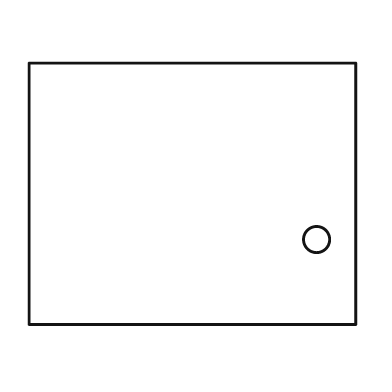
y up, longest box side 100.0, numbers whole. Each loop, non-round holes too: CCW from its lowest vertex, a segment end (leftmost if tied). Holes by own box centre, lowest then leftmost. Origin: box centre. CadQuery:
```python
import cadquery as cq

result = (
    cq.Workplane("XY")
    .moveTo(-50.0, -40.0)
    .lineTo(50.0, -40.0)
    .lineTo(50.0, 40.0)
    .lineTo(-50.0, 40.0)
    .close()
    .moveTo(38.0, -14.0)
    .circle(4.0)
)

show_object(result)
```